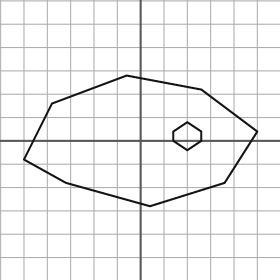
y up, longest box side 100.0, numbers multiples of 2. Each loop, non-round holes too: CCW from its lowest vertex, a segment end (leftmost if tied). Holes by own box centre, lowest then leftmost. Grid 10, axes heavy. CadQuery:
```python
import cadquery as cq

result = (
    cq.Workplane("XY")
    .moveTo(4.0, -28.0)
    .lineTo(36.0, -18.0)
    .lineTo(50.0, 4.0)
    .lineTo(26.0, 22.0)
    .lineTo(-6.0, 28.0)
    .lineTo(-38.0, 16.0)
    .lineTo(-50.0, -8.0)
    .lineTo(-32.0, -18.0)
    .close()
    .moveTo(20.0, -4.0)
    .lineTo(26.0, 0.0)
    .lineTo(26.0, 4.0)
    .lineTo(20.0, 8.0)
    .lineTo(14.0, 4.0)
    .lineTo(14.0, 0.0)
    .close()
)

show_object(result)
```